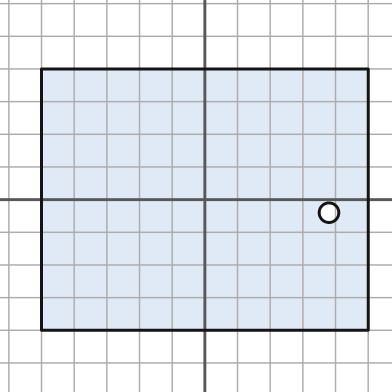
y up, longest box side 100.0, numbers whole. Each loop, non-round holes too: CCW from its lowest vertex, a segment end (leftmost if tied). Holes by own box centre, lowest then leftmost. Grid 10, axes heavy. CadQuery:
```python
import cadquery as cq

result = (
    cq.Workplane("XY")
    .moveTo(-50.0, -40.0)
    .lineTo(50.0, -40.0)
    .lineTo(50.0, 40.0)
    .lineTo(-50.0, 40.0)
    .close()
    .moveTo(38.0, -4.0)
    .circle(3.0)
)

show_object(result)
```